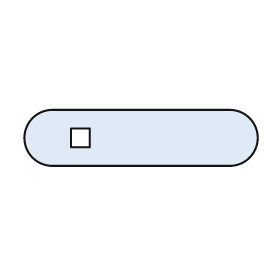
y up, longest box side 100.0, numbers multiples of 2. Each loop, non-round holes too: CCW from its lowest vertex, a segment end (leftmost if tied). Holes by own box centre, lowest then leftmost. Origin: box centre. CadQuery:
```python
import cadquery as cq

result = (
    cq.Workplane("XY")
    .moveTo(-38.0, -12.0)
    .lineTo(38.0, -12.0)
    .threePointArc((50.0, 0.0), (38.0, 12.0))
    .lineTo(-38.0, 12.0)
    .threePointArc((-50.0, 0.0), (-38.0, -12.0))
    .close()
    .moveTo(-30.0, -4.0)
    .lineTo(-22.0, -4.0)
    .lineTo(-22.0, 4.0)
    .lineTo(-30.0, 4.0)
    .close()
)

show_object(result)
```